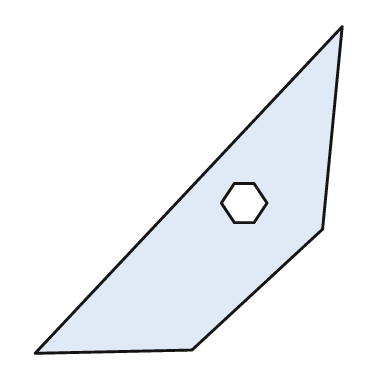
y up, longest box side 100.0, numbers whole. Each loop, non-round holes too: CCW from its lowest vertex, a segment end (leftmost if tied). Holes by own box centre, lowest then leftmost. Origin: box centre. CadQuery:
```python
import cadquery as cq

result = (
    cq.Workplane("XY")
    .moveTo(-47.0, -50.0)
    .lineTo(1.0, -49.0)
    .lineTo(41.0, -12.0)
    .lineTo(47.0, 50.0)
    .close()
    .moveTo(14.0, -10.0)
    .lineTo(20.0, -10.0)
    .lineTo(24.0, -4.0)
    .lineTo(20.0, 2.0)
    .lineTo(14.0, 2.0)
    .lineTo(10.0, -4.0)
    .close()
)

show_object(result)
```